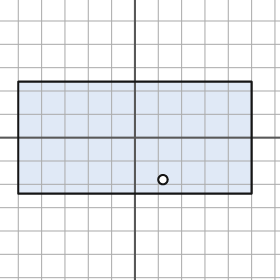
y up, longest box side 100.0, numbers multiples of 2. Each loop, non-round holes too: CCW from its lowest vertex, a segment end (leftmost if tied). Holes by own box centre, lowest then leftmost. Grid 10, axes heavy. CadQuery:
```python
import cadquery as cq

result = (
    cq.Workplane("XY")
    .moveTo(-50.0, -24.0)
    .lineTo(50.0, -24.0)
    .lineTo(50.0, 24.0)
    .lineTo(-50.0, 24.0)
    .close()
    .moveTo(12.0, -18.0)
    .circle(2.0)
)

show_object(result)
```